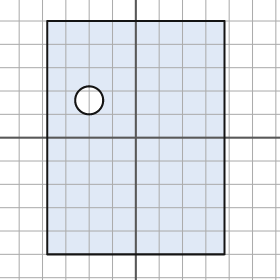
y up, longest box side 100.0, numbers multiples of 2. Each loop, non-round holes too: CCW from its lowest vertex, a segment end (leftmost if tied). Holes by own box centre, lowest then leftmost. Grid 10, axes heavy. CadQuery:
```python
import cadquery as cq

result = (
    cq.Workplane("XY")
    .moveTo(-38.0, -50.0)
    .lineTo(38.0, -50.0)
    .lineTo(38.0, 50.0)
    .lineTo(-38.0, 50.0)
    .close()
    .moveTo(-20.0, 16.0)
    .circle(6.0)
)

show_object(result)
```